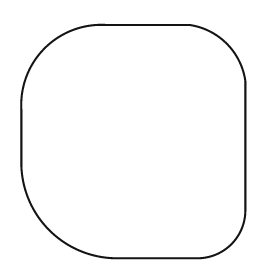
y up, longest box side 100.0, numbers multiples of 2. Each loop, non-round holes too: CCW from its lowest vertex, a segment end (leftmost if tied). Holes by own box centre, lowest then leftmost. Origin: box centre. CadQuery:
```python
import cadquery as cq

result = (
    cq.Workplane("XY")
    .moveTo(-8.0, -50.0)
    .lineTo(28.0, -50.0)
    .threePointArc((42.0, -44.0), (48.0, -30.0))
    .lineTo(48.0, 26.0)
    .threePointArc((40.0, 42.0), (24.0, 50.0))
    .lineTo(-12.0, 50.0)
    .threePointArc((-38.0, 40.0), (-48.0, 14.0))
    .lineTo(-48.0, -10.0)
    .threePointArc((-36.0, -38.0), (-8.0, -50.0))
    .close()
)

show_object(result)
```